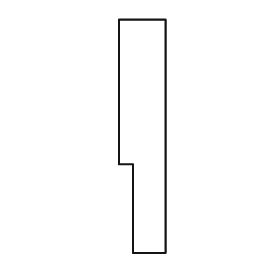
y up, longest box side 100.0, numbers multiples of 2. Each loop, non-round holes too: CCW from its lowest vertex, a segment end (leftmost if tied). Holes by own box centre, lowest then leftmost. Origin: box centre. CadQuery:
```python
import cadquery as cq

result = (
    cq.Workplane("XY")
    .moveTo(-4.0, -50.0)
    .lineTo(10.0, -50.0)
    .lineTo(10.0, 50.0)
    .lineTo(-10.0, 50.0)
    .lineTo(-10.0, -12.0)
    .lineTo(-4.0, -12.0)
    .close()
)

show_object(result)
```